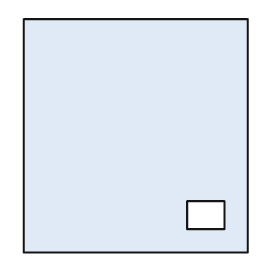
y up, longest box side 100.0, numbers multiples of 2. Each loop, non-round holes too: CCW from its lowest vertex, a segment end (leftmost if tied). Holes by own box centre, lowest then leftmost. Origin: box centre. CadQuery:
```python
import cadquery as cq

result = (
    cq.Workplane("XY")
    .moveTo(-48.0, -50.0)
    .lineTo(48.0, -50.0)
    .lineTo(48.0, 50.0)
    .lineTo(-48.0, 50.0)
    .close()
    .moveTo(22.0, -40.0)
    .lineTo(38.0, -40.0)
    .lineTo(38.0, -28.0)
    .lineTo(22.0, -28.0)
    .close()
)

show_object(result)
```